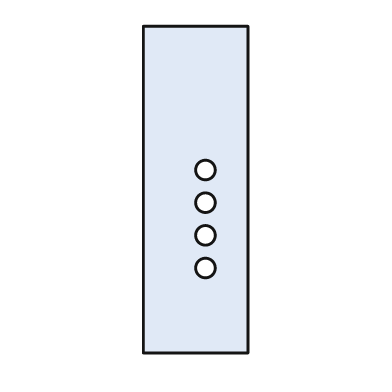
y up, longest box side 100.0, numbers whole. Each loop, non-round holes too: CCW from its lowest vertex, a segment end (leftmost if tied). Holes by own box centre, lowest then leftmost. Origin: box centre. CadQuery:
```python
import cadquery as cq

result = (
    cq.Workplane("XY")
    .moveTo(-16.0, -50.0)
    .lineTo(16.0, -50.0)
    .lineTo(16.0, 50.0)
    .lineTo(-16.0, 50.0)
    .close()
    .moveTo(3.0, -24.0)
    .circle(3.0)
    .moveTo(3.0, -14.0)
    .circle(3.0)
    .moveTo(3.0, -4.0)
    .circle(3.0)
    .moveTo(3.0, 6.0)
    .circle(3.0)
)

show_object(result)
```